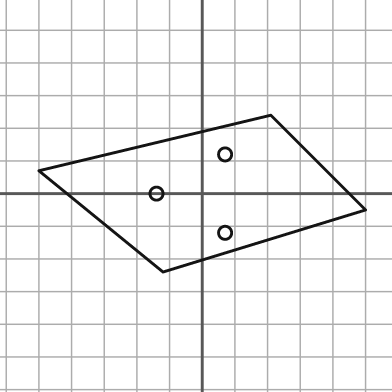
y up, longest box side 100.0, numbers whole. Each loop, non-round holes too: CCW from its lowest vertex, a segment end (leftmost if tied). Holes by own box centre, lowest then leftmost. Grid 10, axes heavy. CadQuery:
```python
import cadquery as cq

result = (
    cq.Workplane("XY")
    .moveTo(-12.0, -24.0)
    .lineTo(50.0, -5.0)
    .lineTo(21.0, 24.0)
    .lineTo(-50.0, 7.0)
    .close()
    .moveTo(7.0, -12.0)
    .circle(2.0)
    .moveTo(-14.0, 0.0)
    .circle(2.0)
    .moveTo(7.0, 12.0)
    .circle(2.0)
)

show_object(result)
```